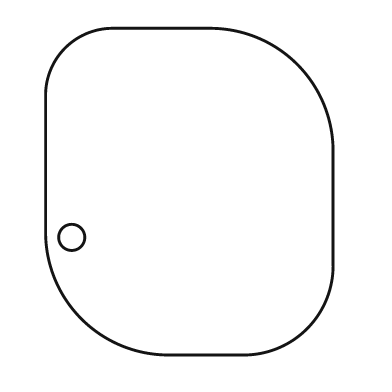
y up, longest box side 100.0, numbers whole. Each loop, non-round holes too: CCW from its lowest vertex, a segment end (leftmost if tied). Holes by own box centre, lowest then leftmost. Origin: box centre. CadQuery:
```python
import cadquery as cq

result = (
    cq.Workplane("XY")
    .moveTo(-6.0, -50.0)
    .lineTo(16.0, -50.0)
    .threePointArc((36.0, -42.0), (44.0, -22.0))
    .lineTo(44.0, 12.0)
    .threePointArc((33.0, 39.0), (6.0, 50.0))
    .lineTo(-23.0, 50.0)
    .threePointArc((-38.0, 44.0), (-44.0, 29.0))
    .lineTo(-44.0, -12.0)
    .threePointArc((-33.0, -39.0), (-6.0, -50.0))
    .close()
    .moveTo(-36.0, -14.0)
    .circle(4.0)
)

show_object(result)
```